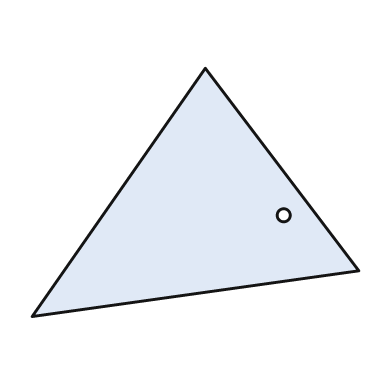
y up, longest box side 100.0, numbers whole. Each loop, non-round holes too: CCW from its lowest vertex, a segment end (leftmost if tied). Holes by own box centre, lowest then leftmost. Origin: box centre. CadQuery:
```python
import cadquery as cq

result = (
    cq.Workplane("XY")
    .moveTo(-50.0, -38.0)
    .lineTo(50.0, -24.0)
    .lineTo(3.0, 38.0)
    .close()
    .moveTo(27.0, -7.0)
    .circle(2.0)
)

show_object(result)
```